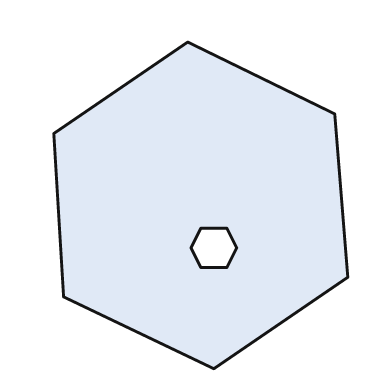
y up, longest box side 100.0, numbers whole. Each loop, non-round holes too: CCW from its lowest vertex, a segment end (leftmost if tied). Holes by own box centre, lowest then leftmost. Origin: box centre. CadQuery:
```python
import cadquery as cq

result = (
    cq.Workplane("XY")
    .moveTo(4.0, -50.0)
    .lineTo(45.0, -22.0)
    .lineTo(41.0, 28.0)
    .lineTo(-4.0, 50.0)
    .lineTo(-45.0, 22.0)
    .lineTo(-42.0, -28.0)
    .close()
    .moveTo(0.0, -19.0)
    .lineTo(8.0, -19.0)
    .lineTo(11.0, -13.0)
    .lineTo(8.0, -7.0)
    .lineTo(0.0, -7.0)
    .lineTo(-3.0, -13.0)
    .close()
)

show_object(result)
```